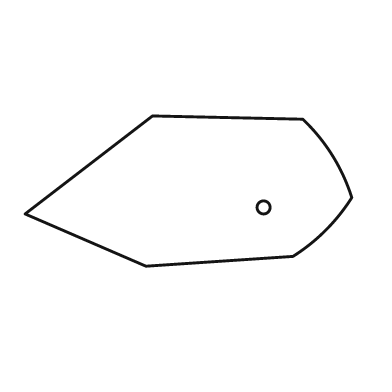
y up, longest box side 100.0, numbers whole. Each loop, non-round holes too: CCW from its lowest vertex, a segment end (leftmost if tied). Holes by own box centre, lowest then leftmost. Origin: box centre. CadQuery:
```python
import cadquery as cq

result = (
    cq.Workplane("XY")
    .moveTo(-13.0, -23.0)
    .lineTo(32.0, -20.0)
    .threePointArc((42.0, -12.0), (50.0, -2.0))
    .threePointArc((44.0, 11.0), (35.0, 22.0))
    .lineTo(-11.0, 23.0)
    .lineTo(-50.0, -7.0)
    .close()
    .moveTo(23.0, -5.0)
    .circle(2.0)
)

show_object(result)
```